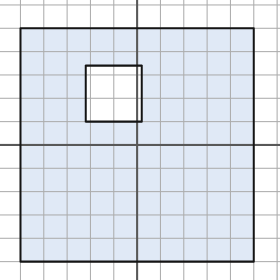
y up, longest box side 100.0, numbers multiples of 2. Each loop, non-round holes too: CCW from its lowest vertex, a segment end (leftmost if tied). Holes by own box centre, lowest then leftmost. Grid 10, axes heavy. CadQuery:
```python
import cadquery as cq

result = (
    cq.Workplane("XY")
    .moveTo(-50.0, -50.0)
    .lineTo(50.0, -50.0)
    .lineTo(50.0, 50.0)
    .lineTo(-50.0, 50.0)
    .close()
    .moveTo(-22.0, 10.0)
    .lineTo(2.0, 10.0)
    .lineTo(2.0, 34.0)
    .lineTo(-22.0, 34.0)
    .close()
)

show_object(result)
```